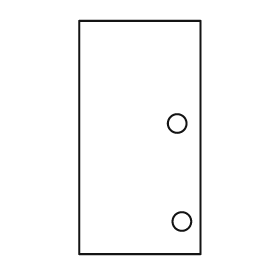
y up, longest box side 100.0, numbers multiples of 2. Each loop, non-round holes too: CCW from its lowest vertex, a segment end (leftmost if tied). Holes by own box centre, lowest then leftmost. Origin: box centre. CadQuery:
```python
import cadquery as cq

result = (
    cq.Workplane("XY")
    .moveTo(-26.0, -50.0)
    .lineTo(26.0, -50.0)
    .lineTo(26.0, 50.0)
    .lineTo(-26.0, 50.0)
    .close()
    .moveTo(18.0, -36.0)
    .circle(4.0)
    .moveTo(16.0, 6.0)
    .circle(4.0)
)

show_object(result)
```